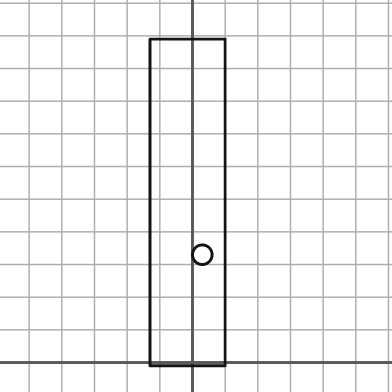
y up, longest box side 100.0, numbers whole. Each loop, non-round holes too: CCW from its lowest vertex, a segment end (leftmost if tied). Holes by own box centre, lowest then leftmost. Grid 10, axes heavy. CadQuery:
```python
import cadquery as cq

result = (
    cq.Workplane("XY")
    .moveTo(-13.0, -1.0)
    .lineTo(10.0, -1.0)
    .lineTo(10.0, 99.0)
    .lineTo(-13.0, 99.0)
    .close()
    .moveTo(3.0, 33.0)
    .circle(3.0)
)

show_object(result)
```